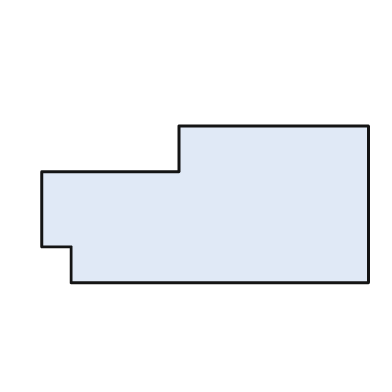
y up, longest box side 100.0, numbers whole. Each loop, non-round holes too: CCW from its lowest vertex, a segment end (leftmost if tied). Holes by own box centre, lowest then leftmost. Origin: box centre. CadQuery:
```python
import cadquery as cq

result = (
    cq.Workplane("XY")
    .moveTo(-41.0, -24.0)
    .lineTo(50.0, -24.0)
    .lineTo(50.0, 24.0)
    .lineTo(-8.0, 24.0)
    .lineTo(-8.0, 10.0)
    .lineTo(-50.0, 10.0)
    .lineTo(-50.0, -13.0)
    .lineTo(-41.0, -13.0)
    .close()
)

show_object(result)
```